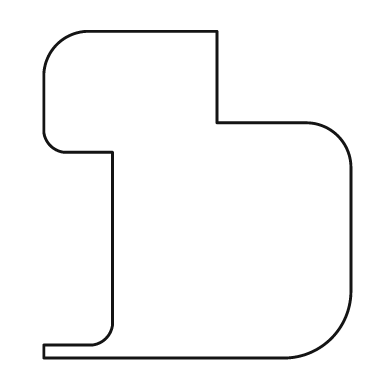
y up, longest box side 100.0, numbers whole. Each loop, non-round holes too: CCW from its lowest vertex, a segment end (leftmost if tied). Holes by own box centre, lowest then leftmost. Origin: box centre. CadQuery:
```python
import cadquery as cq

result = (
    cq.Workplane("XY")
    .moveTo(-47.0, -50.0)
    .lineTo(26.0, -50.0)
    .threePointArc((41.0, -44.0), (47.0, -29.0))
    .lineTo(47.0, 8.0)
    .threePointArc((43.0, 18.0), (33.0, 22.0))
    .lineTo(6.0, 22.0)
    .lineTo(6.0, 50.0)
    .lineTo(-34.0, 50.0)
    .threePointArc((-43.0, 46.0), (-47.0, 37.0))
    .lineTo(-47.0, 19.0)
    .threePointArc((-45.0, 15.0), (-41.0, 13.0))
    .lineTo(-26.0, 13.0)
    .lineTo(-26.0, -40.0)
    .threePointArc((-28.0, -44.0), (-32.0, -46.0))
    .lineTo(-47.0, -46.0)
    .close()
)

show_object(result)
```